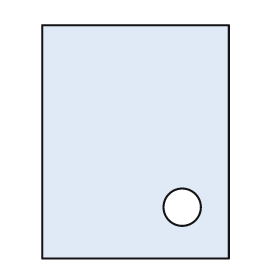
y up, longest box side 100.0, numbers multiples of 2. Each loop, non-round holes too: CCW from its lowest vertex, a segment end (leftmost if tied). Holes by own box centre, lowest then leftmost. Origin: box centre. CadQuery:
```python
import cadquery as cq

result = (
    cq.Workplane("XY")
    .moveTo(-40.0, -50.0)
    .lineTo(40.0, -50.0)
    .lineTo(40.0, 50.0)
    .lineTo(-40.0, 50.0)
    .close()
    .moveTo(20.0, -28.0)
    .circle(8.0)
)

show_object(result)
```